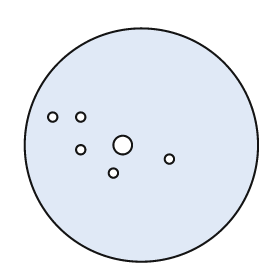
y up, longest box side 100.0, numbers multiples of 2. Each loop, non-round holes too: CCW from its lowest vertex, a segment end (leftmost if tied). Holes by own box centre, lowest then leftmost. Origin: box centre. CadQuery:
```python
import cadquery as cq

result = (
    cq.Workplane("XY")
    .moveTo(0.0, 0.0)
    .circle(50.0)
    .moveTo(-12.0, -12.0)
    .circle(2.0)
    .moveTo(12.0, -6.0)
    .circle(2.0)
    .moveTo(-26.0, -2.0)
    .circle(2.0)
    .moveTo(-8.0, 0.0)
    .circle(4.0)
    .moveTo(-38.0, 12.0)
    .circle(2.0)
    .moveTo(-26.0, 12.0)
    .circle(2.0)
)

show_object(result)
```